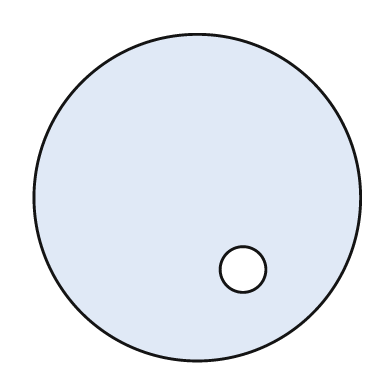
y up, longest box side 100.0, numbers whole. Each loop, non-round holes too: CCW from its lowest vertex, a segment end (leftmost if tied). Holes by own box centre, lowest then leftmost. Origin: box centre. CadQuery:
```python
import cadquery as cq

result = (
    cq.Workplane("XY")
    .moveTo(0.0, 0.0)
    .circle(50.0)
    .moveTo(14.0, -22.0)
    .circle(7.0)
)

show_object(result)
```